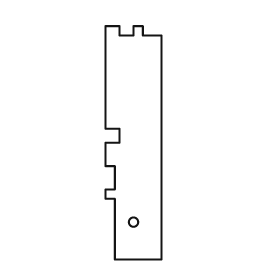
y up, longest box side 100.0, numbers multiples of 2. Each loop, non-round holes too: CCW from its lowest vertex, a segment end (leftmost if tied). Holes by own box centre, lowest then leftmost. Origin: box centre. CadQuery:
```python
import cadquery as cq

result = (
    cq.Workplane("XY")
    .moveTo(-8.0, -50.0)
    .lineTo(12.0, -50.0)
    .lineTo(12.0, 46.0)
    .lineTo(4.0, 46.0)
    .lineTo(4.0, 50.0)
    .lineTo(0.0, 50.0)
    .lineTo(0.0, 46.0)
    .lineTo(-6.0, 46.0)
    .lineTo(-6.0, 50.0)
    .lineTo(-12.0, 50.0)
    .lineTo(-12.0, 6.0)
    .lineTo(-6.0, 6.0)
    .lineTo(-6.0, 0.0)
    .lineTo(-12.0, 0.0)
    .lineTo(-12.0, -10.0)
    .lineTo(-8.0, -10.0)
    .lineTo(-8.0, -20.0)
    .lineTo(-12.0, -20.0)
    .lineTo(-12.0, -24.0)
    .lineTo(-8.0, -24.0)
    .close()
    .moveTo(0.0, -34.0)
    .circle(2.0)
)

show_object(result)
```